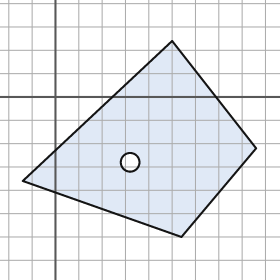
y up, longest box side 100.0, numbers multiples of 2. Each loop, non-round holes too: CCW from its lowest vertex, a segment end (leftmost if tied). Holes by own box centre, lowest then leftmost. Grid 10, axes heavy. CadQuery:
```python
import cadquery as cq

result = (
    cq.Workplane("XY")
    .moveTo(54.0, -60.0)
    .lineTo(86.0, -22.0)
    .lineTo(50.0, 24.0)
    .lineTo(-14.0, -36.0)
    .close()
    .moveTo(32.0, -28.0)
    .circle(4.0)
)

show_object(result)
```